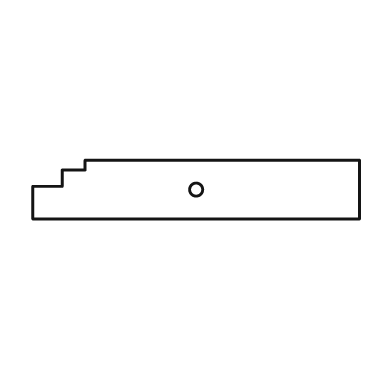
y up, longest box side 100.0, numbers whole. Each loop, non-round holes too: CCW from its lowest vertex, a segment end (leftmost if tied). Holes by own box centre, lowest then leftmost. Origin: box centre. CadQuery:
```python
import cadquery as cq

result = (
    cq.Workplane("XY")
    .moveTo(-50.0, -9.0)
    .lineTo(50.0, -9.0)
    .lineTo(50.0, 9.0)
    .lineTo(-34.0, 9.0)
    .lineTo(-34.0, 6.0)
    .lineTo(-41.0, 6.0)
    .lineTo(-41.0, 1.0)
    .lineTo(-50.0, 1.0)
    .close()
    .moveTo(0.0, 0.0)
    .circle(2.0)
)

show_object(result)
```